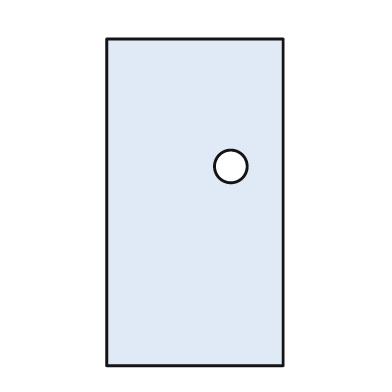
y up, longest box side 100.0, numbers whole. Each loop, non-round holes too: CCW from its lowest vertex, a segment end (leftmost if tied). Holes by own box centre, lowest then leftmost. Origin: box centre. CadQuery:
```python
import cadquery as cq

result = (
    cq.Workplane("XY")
    .moveTo(-27.0, -50.0)
    .lineTo(27.0, -50.0)
    .lineTo(27.0, 50.0)
    .lineTo(-27.0, 50.0)
    .close()
    .moveTo(11.0, 11.0)
    .circle(5.0)
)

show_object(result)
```